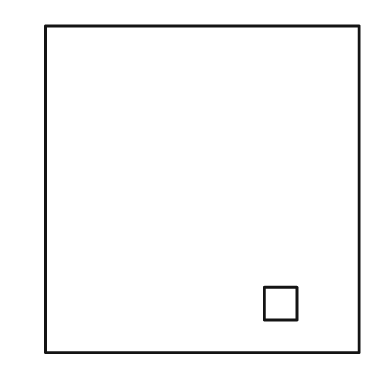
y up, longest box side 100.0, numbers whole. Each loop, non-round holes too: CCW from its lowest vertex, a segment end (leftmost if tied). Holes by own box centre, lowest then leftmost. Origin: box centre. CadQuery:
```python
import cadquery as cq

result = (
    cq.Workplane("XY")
    .moveTo(-48.0, -50.0)
    .lineTo(48.0, -50.0)
    .lineTo(48.0, 50.0)
    .lineTo(-48.0, 50.0)
    .close()
    .moveTo(19.0, -40.0)
    .lineTo(29.0, -40.0)
    .lineTo(29.0, -30.0)
    .lineTo(19.0, -30.0)
    .close()
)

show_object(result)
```